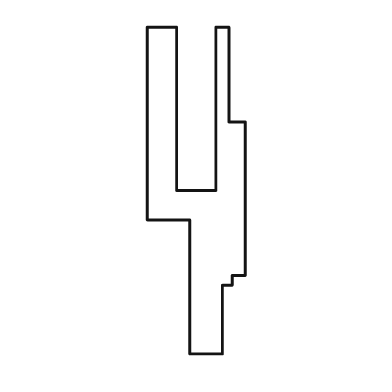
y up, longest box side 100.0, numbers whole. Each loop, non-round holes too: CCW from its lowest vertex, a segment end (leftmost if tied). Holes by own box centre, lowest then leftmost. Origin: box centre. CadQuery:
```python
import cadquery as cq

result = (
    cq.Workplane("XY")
    .moveTo(-2.0, -50.0)
    .lineTo(8.0, -50.0)
    .lineTo(8.0, -29.0)
    .lineTo(11.0, -29.0)
    .lineTo(11.0, -26.0)
    .lineTo(15.0, -26.0)
    .lineTo(15.0, 21.0)
    .lineTo(10.0, 21.0)
    .lineTo(10.0, 50.0)
    .lineTo(6.0, 50.0)
    .lineTo(6.0, 0.0)
    .lineTo(-6.0, 0.0)
    .lineTo(-6.0, 50.0)
    .lineTo(-15.0, 50.0)
    .lineTo(-15.0, -9.0)
    .lineTo(-2.0, -9.0)
    .close()
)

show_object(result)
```